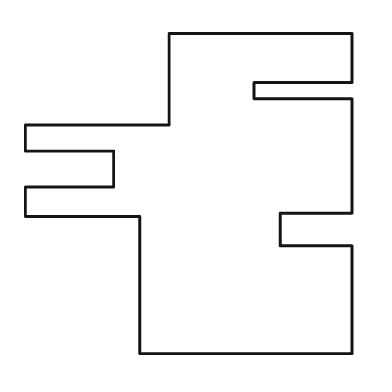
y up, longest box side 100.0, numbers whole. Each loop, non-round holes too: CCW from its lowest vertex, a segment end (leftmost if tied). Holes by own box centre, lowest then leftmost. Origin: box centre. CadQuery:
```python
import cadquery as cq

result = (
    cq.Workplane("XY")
    .moveTo(-15.0, -49.0)
    .lineTo(50.0, -49.0)
    .lineTo(50.0, -16.0)
    .lineTo(28.0, -16.0)
    .lineTo(28.0, -6.0)
    .lineTo(50.0, -6.0)
    .lineTo(50.0, 29.0)
    .lineTo(20.0, 29.0)
    .lineTo(20.0, 34.0)
    .lineTo(50.0, 34.0)
    .lineTo(50.0, 49.0)
    .lineTo(-6.0, 49.0)
    .lineTo(-6.0, 21.0)
    .lineTo(-50.0, 21.0)
    .lineTo(-50.0, 13.0)
    .lineTo(-23.0, 13.0)
    .lineTo(-23.0, 2.0)
    .lineTo(-50.0, 2.0)
    .lineTo(-50.0, -7.0)
    .lineTo(-15.0, -7.0)
    .close()
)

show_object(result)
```